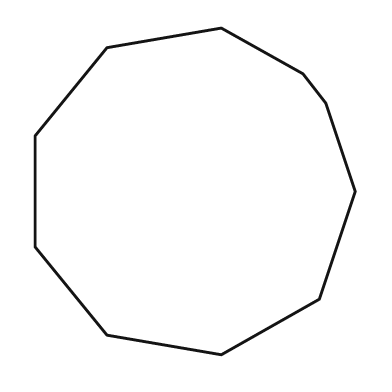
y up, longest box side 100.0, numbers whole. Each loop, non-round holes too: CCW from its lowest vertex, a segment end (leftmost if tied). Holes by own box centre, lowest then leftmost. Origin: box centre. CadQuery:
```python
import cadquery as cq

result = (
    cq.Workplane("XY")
    .moveTo(8.0, -50.0)
    .lineTo(38.0, -33.0)
    .lineTo(49.0, 0.0)
    .lineTo(40.0, 27.0)
    .lineTo(33.0, 36.0)
    .lineTo(8.0, 50.0)
    .lineTo(-27.0, 44.0)
    .lineTo(-49.0, 17.0)
    .lineTo(-49.0, -17.0)
    .lineTo(-27.0, -44.0)
    .close()
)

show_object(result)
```